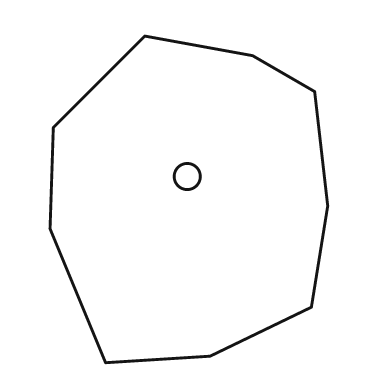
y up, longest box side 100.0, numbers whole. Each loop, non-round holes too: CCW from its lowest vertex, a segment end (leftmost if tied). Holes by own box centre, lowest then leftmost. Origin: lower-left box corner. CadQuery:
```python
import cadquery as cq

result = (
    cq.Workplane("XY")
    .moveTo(17.0, 0.0)
    .lineTo(49.0, 2.0)
    .lineTo(80.0, 17.0)
    .lineTo(85.0, 48.0)
    .lineTo(81.0, 83.0)
    .lineTo(62.0, 94.0)
    .lineTo(29.0, 100.0)
    .lineTo(1.0, 72.0)
    .lineTo(0.0, 41.0)
    .close()
    .moveTo(42.0, 57.0)
    .circle(4.0)
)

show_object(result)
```